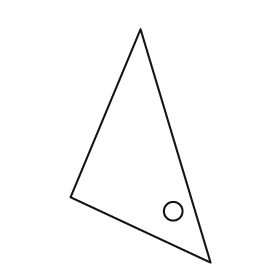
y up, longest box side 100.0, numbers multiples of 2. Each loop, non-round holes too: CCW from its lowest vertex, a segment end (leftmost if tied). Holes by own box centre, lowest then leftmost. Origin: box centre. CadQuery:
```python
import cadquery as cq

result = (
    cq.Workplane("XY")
    .moveTo(30.0, -50.0)
    .lineTo(0.0, 50.0)
    .lineTo(-30.0, -22.0)
    .close()
    .moveTo(14.0, -28.0)
    .circle(4.0)
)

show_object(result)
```